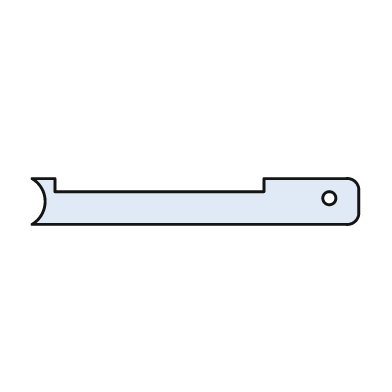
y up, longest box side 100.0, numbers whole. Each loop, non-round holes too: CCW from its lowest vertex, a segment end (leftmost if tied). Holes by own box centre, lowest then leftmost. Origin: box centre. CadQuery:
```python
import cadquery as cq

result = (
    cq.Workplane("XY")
    .moveTo(-50.0, -7.0)
    .lineTo(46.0, -7.0)
    .threePointArc((49.0, -6.0), (50.0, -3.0))
    .lineTo(50.0, 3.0)
    .threePointArc((49.0, 6.0), (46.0, 7.0))
    .lineTo(21.0, 7.0)
    .lineTo(21.0, 3.0)
    .lineTo(-43.0, 3.0)
    .lineTo(-43.0, 7.0)
    .lineTo(-50.0, 7.0)
    .threePointArc((-46.0, 0.0), (-50.0, -7.0))
    .close()
    .moveTo(41.0, 1.0)
    .circle(2.0)
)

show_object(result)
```